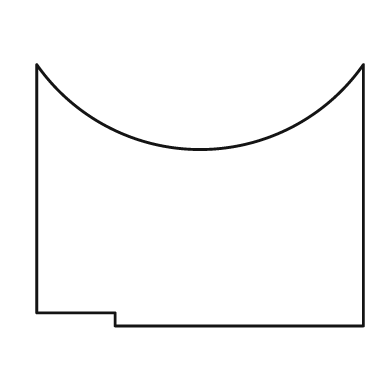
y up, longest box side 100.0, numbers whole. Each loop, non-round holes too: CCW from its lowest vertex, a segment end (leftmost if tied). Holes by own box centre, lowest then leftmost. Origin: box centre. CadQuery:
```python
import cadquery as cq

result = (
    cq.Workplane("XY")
    .moveTo(-26.0, -40.0)
    .lineTo(50.0, -40.0)
    .lineTo(50.0, 40.0)
    .threePointArc((0.0, 14.0), (-50.0, 40.0))
    .lineTo(-50.0, -36.0)
    .lineTo(-26.0, -36.0)
    .close()
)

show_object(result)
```